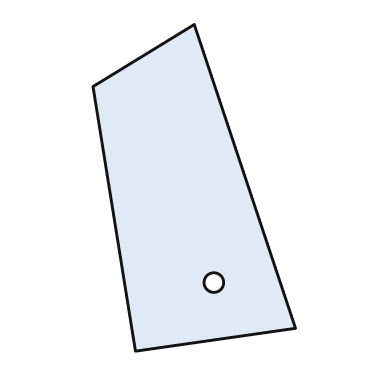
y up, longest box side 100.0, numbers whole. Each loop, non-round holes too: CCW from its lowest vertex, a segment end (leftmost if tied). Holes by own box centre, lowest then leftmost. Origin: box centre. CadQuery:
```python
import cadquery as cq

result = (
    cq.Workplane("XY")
    .moveTo(-18.0, -50.0)
    .lineTo(31.0, -43.0)
    .lineTo(0.0, 50.0)
    .lineTo(-31.0, 31.0)
    .close()
    .moveTo(6.0, -29.0)
    .circle(3.0)
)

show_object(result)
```